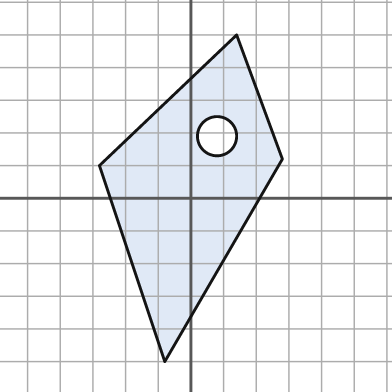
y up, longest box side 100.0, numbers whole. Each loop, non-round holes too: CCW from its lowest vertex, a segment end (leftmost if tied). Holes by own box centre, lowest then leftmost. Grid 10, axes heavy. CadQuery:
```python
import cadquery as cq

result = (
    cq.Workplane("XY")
    .moveTo(-8.0, -50.0)
    .lineTo(28.0, 12.0)
    .lineTo(14.0, 50.0)
    .lineTo(-28.0, 10.0)
    .close()
    .moveTo(8.0, 19.0)
    .circle(6.0)
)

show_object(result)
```